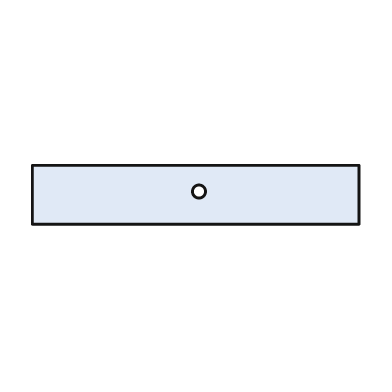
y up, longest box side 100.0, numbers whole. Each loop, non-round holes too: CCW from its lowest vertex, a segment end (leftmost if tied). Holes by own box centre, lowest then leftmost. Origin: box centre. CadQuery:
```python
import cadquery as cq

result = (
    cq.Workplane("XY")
    .moveTo(-50.0, -9.0)
    .lineTo(50.0, -9.0)
    .lineTo(50.0, 9.0)
    .lineTo(-50.0, 9.0)
    .close()
    .moveTo(1.0, 1.0)
    .circle(2.0)
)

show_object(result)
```